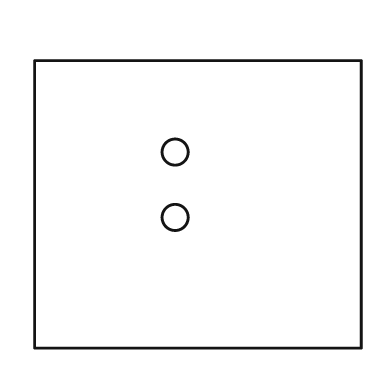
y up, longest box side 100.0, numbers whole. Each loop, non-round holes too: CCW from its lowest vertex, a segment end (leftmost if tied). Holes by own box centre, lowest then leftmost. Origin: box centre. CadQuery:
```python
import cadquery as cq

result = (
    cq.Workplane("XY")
    .moveTo(-50.0, -44.0)
    .lineTo(50.0, -44.0)
    .lineTo(50.0, 44.0)
    .lineTo(-50.0, 44.0)
    .close()
    .moveTo(-7.0, -4.0)
    .circle(4.0)
    .moveTo(-7.0, 16.0)
    .circle(4.0)
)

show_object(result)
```